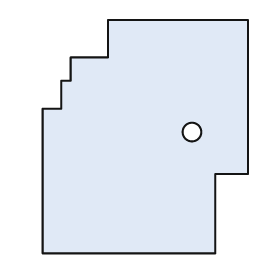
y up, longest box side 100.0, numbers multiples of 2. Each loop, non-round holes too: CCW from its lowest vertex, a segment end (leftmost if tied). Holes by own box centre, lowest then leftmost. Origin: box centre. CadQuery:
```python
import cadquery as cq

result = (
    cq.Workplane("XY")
    .moveTo(-44.0, -50.0)
    .lineTo(30.0, -50.0)
    .lineTo(30.0, -16.0)
    .lineTo(44.0, -16.0)
    .lineTo(44.0, 50.0)
    .lineTo(-16.0, 50.0)
    .lineTo(-16.0, 34.0)
    .lineTo(-32.0, 34.0)
    .lineTo(-32.0, 24.0)
    .lineTo(-36.0, 24.0)
    .lineTo(-36.0, 12.0)
    .lineTo(-44.0, 12.0)
    .close()
    .moveTo(20.0, 2.0)
    .circle(4.0)
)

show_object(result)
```